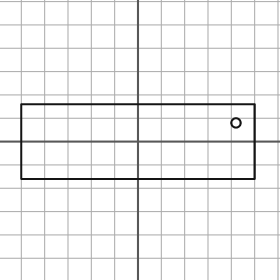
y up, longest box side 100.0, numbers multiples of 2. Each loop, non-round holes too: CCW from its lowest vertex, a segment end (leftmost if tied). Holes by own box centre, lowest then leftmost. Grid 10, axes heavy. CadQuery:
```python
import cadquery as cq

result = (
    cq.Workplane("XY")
    .moveTo(-50.0, -16.0)
    .lineTo(50.0, -16.0)
    .lineTo(50.0, 16.0)
    .lineTo(-50.0, 16.0)
    .close()
    .moveTo(42.0, 8.0)
    .circle(2.0)
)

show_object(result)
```